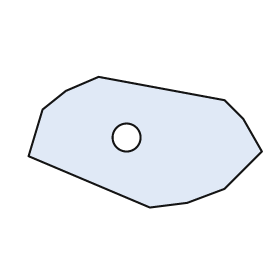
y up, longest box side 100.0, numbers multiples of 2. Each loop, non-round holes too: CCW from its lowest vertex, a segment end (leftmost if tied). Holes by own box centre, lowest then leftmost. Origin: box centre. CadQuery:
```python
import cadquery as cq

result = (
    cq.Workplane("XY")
    .moveTo(2.0, -28.0)
    .lineTo(18.0, -26.0)
    .lineTo(34.0, -20.0)
    .lineTo(50.0, -4.0)
    .lineTo(42.0, 10.0)
    .lineTo(34.0, 18.0)
    .lineTo(-20.0, 28.0)
    .lineTo(-34.0, 22.0)
    .lineTo(-44.0, 14.0)
    .lineTo(-50.0, -6.0)
    .close()
    .moveTo(-8.0, 2.0)
    .circle(6.0)
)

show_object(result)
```